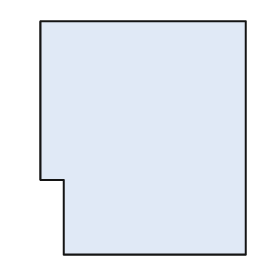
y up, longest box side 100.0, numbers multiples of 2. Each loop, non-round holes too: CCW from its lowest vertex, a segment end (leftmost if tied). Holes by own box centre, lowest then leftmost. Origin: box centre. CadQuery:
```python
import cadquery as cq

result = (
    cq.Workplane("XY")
    .moveTo(-34.0, -50.0)
    .lineTo(44.0, -50.0)
    .lineTo(44.0, 50.0)
    .lineTo(-44.0, 50.0)
    .lineTo(-44.0, -18.0)
    .lineTo(-34.0, -18.0)
    .close()
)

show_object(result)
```